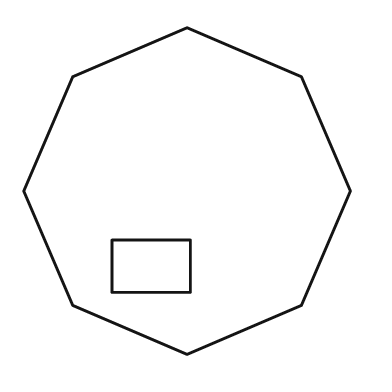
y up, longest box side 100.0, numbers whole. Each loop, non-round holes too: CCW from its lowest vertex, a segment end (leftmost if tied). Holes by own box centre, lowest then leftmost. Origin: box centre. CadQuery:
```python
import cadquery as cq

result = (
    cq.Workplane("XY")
    .moveTo(0.0, -50.0)
    .lineTo(35.0, -35.0)
    .lineTo(50.0, 0.0)
    .lineTo(35.0, 35.0)
    .lineTo(0.0, 50.0)
    .lineTo(-35.0, 35.0)
    .lineTo(-50.0, 0.0)
    .lineTo(-35.0, -35.0)
    .close()
    .moveTo(-23.0, -31.0)
    .lineTo(1.0, -31.0)
    .lineTo(1.0, -15.0)
    .lineTo(-23.0, -15.0)
    .close()
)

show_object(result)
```